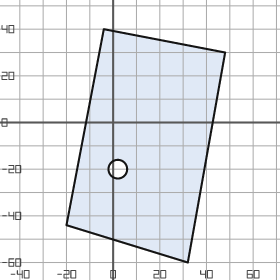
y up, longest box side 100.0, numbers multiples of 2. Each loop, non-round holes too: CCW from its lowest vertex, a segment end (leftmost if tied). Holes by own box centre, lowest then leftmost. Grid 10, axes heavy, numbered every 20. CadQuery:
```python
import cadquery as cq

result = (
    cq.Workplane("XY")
    .moveTo(32.0, -60.0)
    .lineTo(48.0, 30.0)
    .lineTo(-4.0, 40.0)
    .lineTo(-20.0, -44.0)
    .close()
    .moveTo(2.0, -20.0)
    .circle(4.0)
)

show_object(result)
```